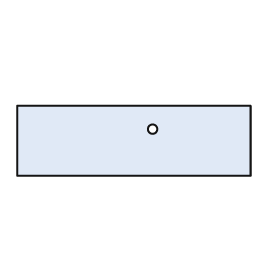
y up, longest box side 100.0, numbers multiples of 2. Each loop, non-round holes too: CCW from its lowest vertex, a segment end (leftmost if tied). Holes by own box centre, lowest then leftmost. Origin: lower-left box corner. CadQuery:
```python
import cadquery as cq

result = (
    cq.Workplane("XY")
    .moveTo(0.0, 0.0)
    .lineTo(100.0, 0.0)
    .lineTo(100.0, 30.0)
    .lineTo(0.0, 30.0)
    .close()
    .moveTo(58.0, 20.0)
    .circle(2.0)
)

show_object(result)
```